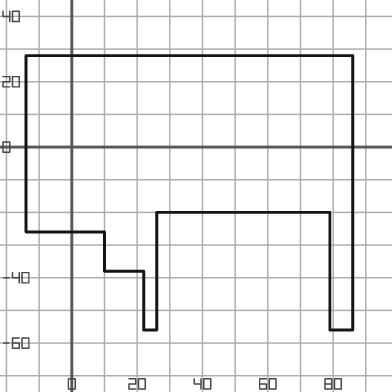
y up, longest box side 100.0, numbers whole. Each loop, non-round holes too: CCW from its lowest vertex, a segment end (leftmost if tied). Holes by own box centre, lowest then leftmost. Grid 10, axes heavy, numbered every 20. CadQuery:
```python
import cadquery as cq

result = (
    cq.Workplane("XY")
    .moveTo(22.0, -56.0)
    .lineTo(26.0, -56.0)
    .lineTo(26.0, -20.0)
    .lineTo(79.0, -20.0)
    .lineTo(79.0, -56.0)
    .lineTo(86.0, -56.0)
    .lineTo(86.0, 28.0)
    .lineTo(-14.0, 28.0)
    .lineTo(-14.0, -26.0)
    .lineTo(10.0, -26.0)
    .lineTo(10.0, -38.0)
    .lineTo(22.0, -38.0)
    .close()
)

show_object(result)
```